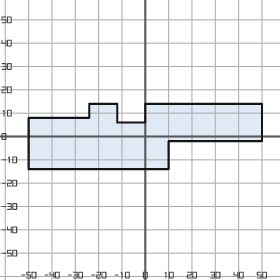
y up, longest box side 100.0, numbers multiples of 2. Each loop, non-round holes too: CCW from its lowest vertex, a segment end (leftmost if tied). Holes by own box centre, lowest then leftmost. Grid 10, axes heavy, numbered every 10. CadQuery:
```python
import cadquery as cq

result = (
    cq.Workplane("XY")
    .moveTo(-50.0, -14.0)
    .lineTo(10.0, -14.0)
    .lineTo(10.0, -2.0)
    .lineTo(50.0, -2.0)
    .lineTo(50.0, 14.0)
    .lineTo(0.0, 14.0)
    .lineTo(0.0, 6.0)
    .lineTo(-12.0, 6.0)
    .lineTo(-12.0, 14.0)
    .lineTo(-24.0, 14.0)
    .lineTo(-24.0, 8.0)
    .lineTo(-50.0, 8.0)
    .close()
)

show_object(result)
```